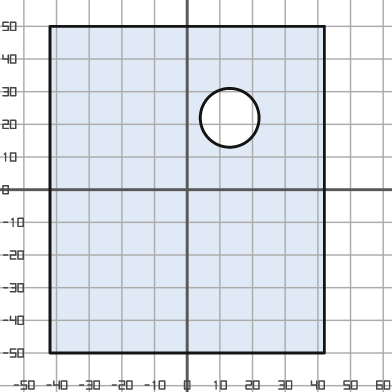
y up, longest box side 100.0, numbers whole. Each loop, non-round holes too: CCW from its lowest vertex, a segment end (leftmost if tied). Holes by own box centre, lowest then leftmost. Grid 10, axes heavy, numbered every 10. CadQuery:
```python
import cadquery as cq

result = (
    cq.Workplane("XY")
    .moveTo(-42.0, -50.0)
    .lineTo(42.0, -50.0)
    .lineTo(42.0, 50.0)
    .lineTo(-42.0, 50.0)
    .close()
    .moveTo(13.0, 22.0)
    .circle(9.0)
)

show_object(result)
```